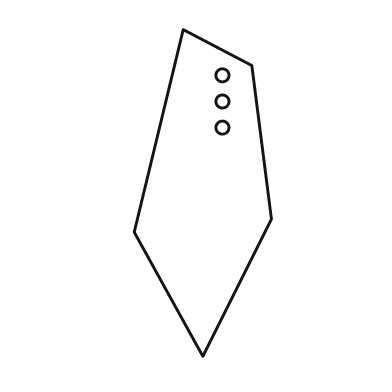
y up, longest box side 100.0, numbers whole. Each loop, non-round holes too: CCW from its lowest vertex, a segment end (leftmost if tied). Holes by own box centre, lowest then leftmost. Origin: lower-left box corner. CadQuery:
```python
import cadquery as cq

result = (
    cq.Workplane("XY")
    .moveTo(21.0, 0.0)
    .lineTo(42.0, 42.0)
    .lineTo(36.0, 89.0)
    .lineTo(15.0, 100.0)
    .lineTo(0.0, 38.0)
    .close()
    .moveTo(27.0, 70.0)
    .circle(2.0)
    .moveTo(27.0, 78.0)
    .circle(2.0)
    .moveTo(27.0, 86.0)
    .circle(2.0)
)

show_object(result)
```